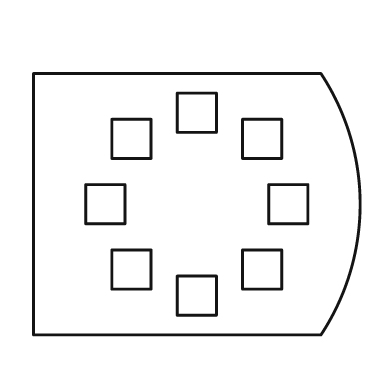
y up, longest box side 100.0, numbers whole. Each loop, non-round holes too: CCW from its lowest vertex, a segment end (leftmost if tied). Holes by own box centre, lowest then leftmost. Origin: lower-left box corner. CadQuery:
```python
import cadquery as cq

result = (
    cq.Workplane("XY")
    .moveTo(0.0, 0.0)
    .lineTo(88.0, 0.0)
    .threePointArc((100.0, 40.0), (88.0, 80.0))
    .lineTo(0.0, 80.0)
    .close()
    .moveTo(44.0, 6.0)
    .lineTo(56.0, 6.0)
    .lineTo(56.0, 18.0)
    .lineTo(44.0, 18.0)
    .close()
    .moveTo(24.0, 14.0)
    .lineTo(36.0, 14.0)
    .lineTo(36.0, 26.0)
    .lineTo(24.0, 26.0)
    .close()
    .moveTo(64.0, 14.0)
    .lineTo(76.0, 14.0)
    .lineTo(76.0, 26.0)
    .lineTo(64.0, 26.0)
    .close()
    .moveTo(16.0, 34.0)
    .lineTo(28.0, 34.0)
    .lineTo(28.0, 46.0)
    .lineTo(16.0, 46.0)
    .close()
    .moveTo(72.0, 34.0)
    .lineTo(84.0, 34.0)
    .lineTo(84.0, 46.0)
    .lineTo(72.0, 46.0)
    .close()
    .moveTo(24.0, 54.0)
    .lineTo(36.0, 54.0)
    .lineTo(36.0, 66.0)
    .lineTo(24.0, 66.0)
    .close()
    .moveTo(64.0, 54.0)
    .lineTo(76.0, 54.0)
    .lineTo(76.0, 66.0)
    .lineTo(64.0, 66.0)
    .close()
    .moveTo(44.0, 62.0)
    .lineTo(56.0, 62.0)
    .lineTo(56.0, 74.0)
    .lineTo(44.0, 74.0)
    .close()
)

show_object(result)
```